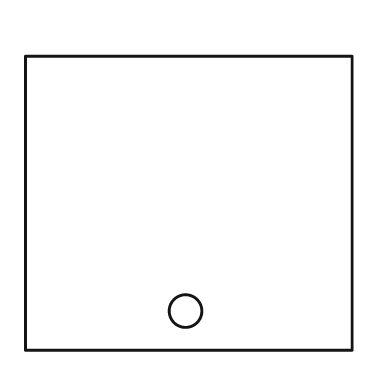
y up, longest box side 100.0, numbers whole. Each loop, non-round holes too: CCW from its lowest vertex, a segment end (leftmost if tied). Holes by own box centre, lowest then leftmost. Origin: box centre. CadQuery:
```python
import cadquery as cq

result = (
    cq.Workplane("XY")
    .moveTo(-50.0, -45.0)
    .lineTo(50.0, -45.0)
    .lineTo(50.0, 45.0)
    .lineTo(-50.0, 45.0)
    .close()
    .moveTo(-1.0, -33.0)
    .circle(5.0)
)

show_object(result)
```